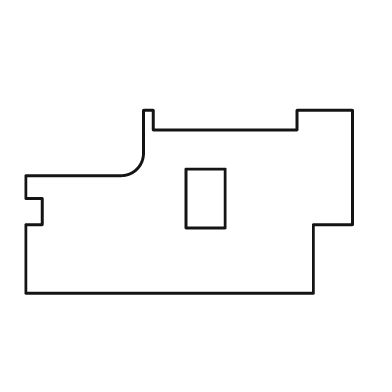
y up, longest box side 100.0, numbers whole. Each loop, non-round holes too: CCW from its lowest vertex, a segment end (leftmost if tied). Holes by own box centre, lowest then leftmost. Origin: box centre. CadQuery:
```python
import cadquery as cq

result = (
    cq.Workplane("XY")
    .moveTo(-50.0, -28.0)
    .lineTo(38.0, -28.0)
    .lineTo(38.0, -7.0)
    .lineTo(50.0, -7.0)
    .lineTo(50.0, 28.0)
    .lineTo(33.0, 28.0)
    .lineTo(33.0, 22.0)
    .lineTo(-11.0, 22.0)
    .lineTo(-11.0, 28.0)
    .lineTo(-14.0, 28.0)
    .lineTo(-14.0, 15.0)
    .threePointArc((-16.0, 10.0), (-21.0, 8.0))
    .lineTo(-50.0, 8.0)
    .lineTo(-50.0, 1.0)
    .lineTo(-45.0, 1.0)
    .lineTo(-45.0, -7.0)
    .lineTo(-50.0, -7.0)
    .close()
    .moveTo(-1.0, -8.0)
    .lineTo(11.0, -8.0)
    .lineTo(11.0, 10.0)
    .lineTo(-1.0, 10.0)
    .close()
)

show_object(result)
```